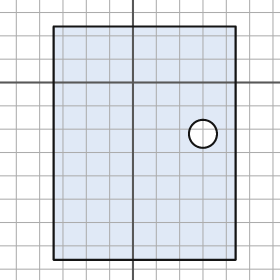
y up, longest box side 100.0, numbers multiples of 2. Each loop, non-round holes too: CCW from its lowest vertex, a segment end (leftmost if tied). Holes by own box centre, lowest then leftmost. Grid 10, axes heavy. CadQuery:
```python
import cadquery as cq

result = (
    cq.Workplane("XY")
    .moveTo(-34.0, -76.0)
    .lineTo(44.0, -76.0)
    .lineTo(44.0, 24.0)
    .lineTo(-34.0, 24.0)
    .close()
    .moveTo(30.0, -22.0)
    .circle(6.0)
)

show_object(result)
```